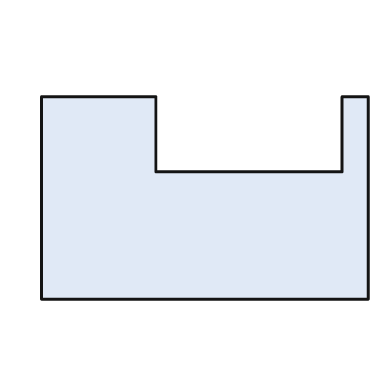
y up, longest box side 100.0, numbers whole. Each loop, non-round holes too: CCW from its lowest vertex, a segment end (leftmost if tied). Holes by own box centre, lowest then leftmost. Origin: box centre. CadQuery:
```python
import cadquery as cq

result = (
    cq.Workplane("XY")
    .moveTo(-50.0, -31.0)
    .lineTo(50.0, -31.0)
    .lineTo(50.0, 31.0)
    .lineTo(42.0, 31.0)
    .lineTo(42.0, 8.0)
    .lineTo(-15.0, 8.0)
    .lineTo(-15.0, 31.0)
    .lineTo(-50.0, 31.0)
    .close()
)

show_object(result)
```